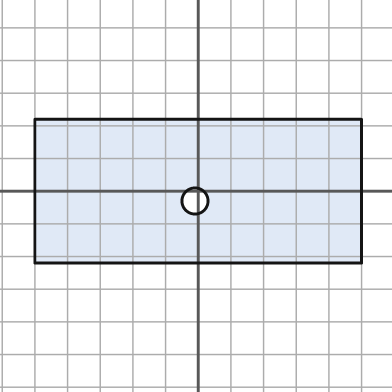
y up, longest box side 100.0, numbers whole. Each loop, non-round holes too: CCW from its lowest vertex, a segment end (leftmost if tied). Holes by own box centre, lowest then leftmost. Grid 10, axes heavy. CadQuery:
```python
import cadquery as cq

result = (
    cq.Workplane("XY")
    .moveTo(-50.0, -22.0)
    .lineTo(50.0, -22.0)
    .lineTo(50.0, 22.0)
    .lineTo(-50.0, 22.0)
    .close()
    .moveTo(-1.0, -3.0)
    .circle(4.0)
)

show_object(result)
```